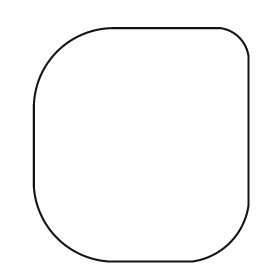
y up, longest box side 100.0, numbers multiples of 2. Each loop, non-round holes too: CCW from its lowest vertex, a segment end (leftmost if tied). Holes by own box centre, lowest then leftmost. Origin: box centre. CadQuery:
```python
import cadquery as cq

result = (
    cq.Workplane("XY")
    .moveTo(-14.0, -50.0)
    .lineTo(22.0, -50.0)
    .threePointArc((38.0, -42.0), (46.0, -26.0))
    .lineTo(46.0, 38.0)
    .threePointArc((42.0, 46.0), (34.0, 50.0))
    .lineTo(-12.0, 50.0)
    .threePointArc((-36.0, 40.0), (-46.0, 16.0))
    .lineTo(-46.0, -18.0)
    .threePointArc((-36.0, -40.0), (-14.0, -50.0))
    .close()
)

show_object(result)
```